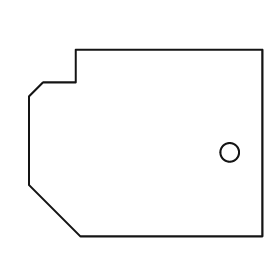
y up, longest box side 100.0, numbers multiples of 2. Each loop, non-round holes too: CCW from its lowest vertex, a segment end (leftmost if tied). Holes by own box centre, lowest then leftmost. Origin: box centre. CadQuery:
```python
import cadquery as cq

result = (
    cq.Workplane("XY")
    .moveTo(-28.0, -40.0)
    .lineTo(50.0, -40.0)
    .lineTo(50.0, 40.0)
    .lineTo(-30.0, 40.0)
    .lineTo(-30.0, 26.0)
    .lineTo(-44.0, 26.0)
    .lineTo(-50.0, 20.0)
    .lineTo(-50.0, -18.0)
    .close()
    .moveTo(36.0, -4.0)
    .circle(4.0)
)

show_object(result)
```